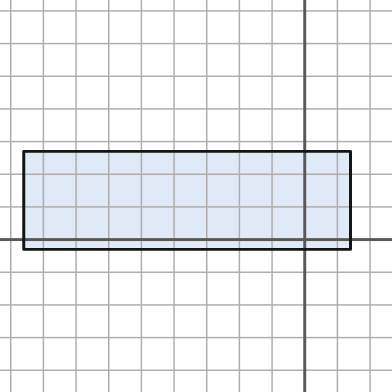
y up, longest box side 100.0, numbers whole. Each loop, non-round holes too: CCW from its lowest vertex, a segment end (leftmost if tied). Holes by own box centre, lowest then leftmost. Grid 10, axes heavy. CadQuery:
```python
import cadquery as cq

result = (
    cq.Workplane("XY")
    .moveTo(-86.0, -3.0)
    .lineTo(14.0, -3.0)
    .lineTo(14.0, 27.0)
    .lineTo(-86.0, 27.0)
    .close()
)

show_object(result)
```